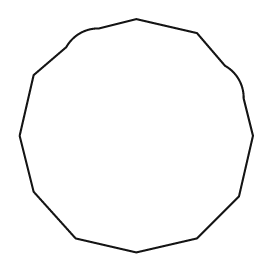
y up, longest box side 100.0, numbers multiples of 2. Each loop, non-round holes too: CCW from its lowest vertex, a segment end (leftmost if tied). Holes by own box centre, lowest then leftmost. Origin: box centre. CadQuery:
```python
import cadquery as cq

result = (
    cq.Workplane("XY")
    .moveTo(0.0, -50.0)
    .lineTo(26.0, -44.0)
    .lineTo(44.0, -26.0)
    .lineTo(50.0, 0.0)
    .lineTo(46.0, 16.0)
    .threePointArc((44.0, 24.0), (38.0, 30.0))
    .lineTo(26.0, 44.0)
    .lineTo(0.0, 50.0)
    .lineTo(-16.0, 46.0)
    .threePointArc((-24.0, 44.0), (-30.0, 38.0))
    .lineTo(-44.0, 26.0)
    .lineTo(-50.0, 0.0)
    .lineTo(-44.0, -24.0)
    .lineTo(-26.0, -44.0)
    .close()
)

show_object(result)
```